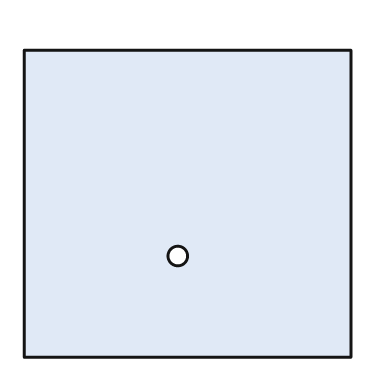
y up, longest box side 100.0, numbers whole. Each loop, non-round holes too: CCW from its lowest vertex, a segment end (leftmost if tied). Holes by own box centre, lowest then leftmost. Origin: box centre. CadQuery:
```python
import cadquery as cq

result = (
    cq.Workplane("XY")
    .moveTo(-50.0, -47.0)
    .lineTo(50.0, -47.0)
    .lineTo(50.0, 47.0)
    .lineTo(-50.0, 47.0)
    .close()
    .moveTo(-3.0, -16.0)
    .circle(3.0)
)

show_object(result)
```